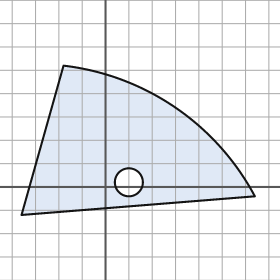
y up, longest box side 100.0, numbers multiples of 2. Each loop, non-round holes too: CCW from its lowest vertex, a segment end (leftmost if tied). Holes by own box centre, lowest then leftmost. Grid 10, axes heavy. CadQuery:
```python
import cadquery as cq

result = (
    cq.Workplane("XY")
    .moveTo(-36.0, -12.0)
    .lineTo(64.0, -4.0)
    .threePointArc((30.0, 34.0), (-18.0, 52.0))
    .close()
    .moveTo(10.0, 2.0)
    .circle(6.0)
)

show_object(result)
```